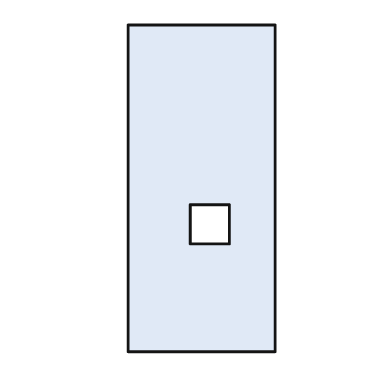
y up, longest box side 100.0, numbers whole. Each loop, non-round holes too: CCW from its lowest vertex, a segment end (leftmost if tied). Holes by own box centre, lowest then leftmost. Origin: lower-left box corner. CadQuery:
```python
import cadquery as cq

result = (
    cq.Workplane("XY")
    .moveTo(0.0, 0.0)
    .lineTo(45.0, 0.0)
    .lineTo(45.0, 100.0)
    .lineTo(0.0, 100.0)
    .close()
    .moveTo(19.0, 33.0)
    .lineTo(31.0, 33.0)
    .lineTo(31.0, 45.0)
    .lineTo(19.0, 45.0)
    .close()
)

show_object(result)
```